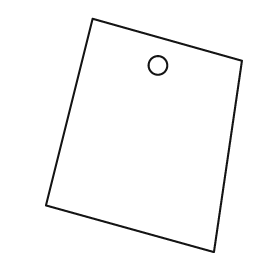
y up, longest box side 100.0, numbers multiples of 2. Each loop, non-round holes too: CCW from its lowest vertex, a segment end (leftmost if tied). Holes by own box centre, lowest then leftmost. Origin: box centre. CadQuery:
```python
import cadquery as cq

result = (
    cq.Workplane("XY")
    .moveTo(30.0, -50.0)
    .lineTo(42.0, 32.0)
    .lineTo(-22.0, 50.0)
    .lineTo(-42.0, -30.0)
    .close()
    .moveTo(6.0, 30.0)
    .circle(4.0)
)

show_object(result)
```